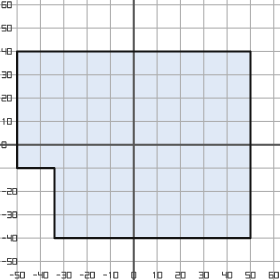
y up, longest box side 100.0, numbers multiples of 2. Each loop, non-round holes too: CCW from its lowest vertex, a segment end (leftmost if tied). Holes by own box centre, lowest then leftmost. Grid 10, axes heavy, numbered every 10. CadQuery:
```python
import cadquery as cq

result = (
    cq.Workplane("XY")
    .moveTo(-34.0, -40.0)
    .lineTo(50.0, -40.0)
    .lineTo(50.0, 40.0)
    .lineTo(-50.0, 40.0)
    .lineTo(-50.0, -10.0)
    .lineTo(-34.0, -10.0)
    .close()
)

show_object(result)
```